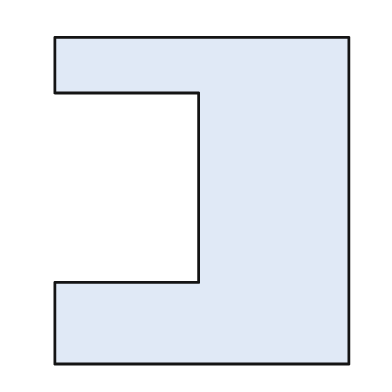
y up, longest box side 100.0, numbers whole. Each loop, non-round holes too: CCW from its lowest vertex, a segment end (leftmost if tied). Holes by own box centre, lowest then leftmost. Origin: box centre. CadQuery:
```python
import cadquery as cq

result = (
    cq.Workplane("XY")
    .moveTo(-45.0, -50.0)
    .lineTo(45.0, -50.0)
    .lineTo(45.0, 50.0)
    .lineTo(-45.0, 50.0)
    .lineTo(-45.0, 33.0)
    .lineTo(-1.0, 33.0)
    .lineTo(-1.0, -25.0)
    .lineTo(-45.0, -25.0)
    .close()
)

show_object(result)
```